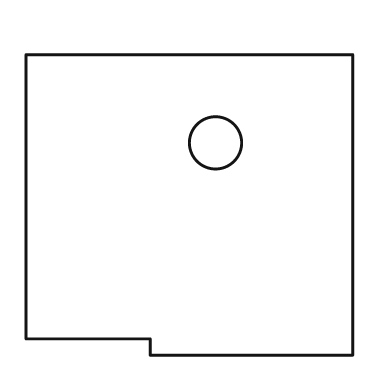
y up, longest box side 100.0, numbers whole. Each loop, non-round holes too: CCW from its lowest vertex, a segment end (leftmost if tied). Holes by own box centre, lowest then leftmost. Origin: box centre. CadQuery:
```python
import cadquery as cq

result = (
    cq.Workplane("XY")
    .moveTo(-12.0, -46.0)
    .lineTo(50.0, -46.0)
    .lineTo(50.0, 46.0)
    .lineTo(-50.0, 46.0)
    .lineTo(-50.0, -41.0)
    .lineTo(-12.0, -41.0)
    .close()
    .moveTo(8.0, 19.0)
    .circle(8.0)
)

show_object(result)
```